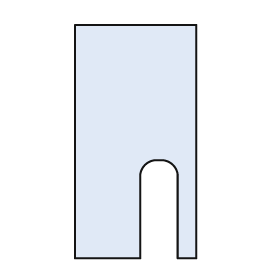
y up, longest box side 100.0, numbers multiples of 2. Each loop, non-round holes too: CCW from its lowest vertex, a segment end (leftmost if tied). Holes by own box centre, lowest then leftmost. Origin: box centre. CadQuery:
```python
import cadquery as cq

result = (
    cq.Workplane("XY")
    .moveTo(-26.0, -50.0)
    .lineTo(2.0, -50.0)
    .lineTo(2.0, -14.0)
    .threePointArc((4.0, -10.0), (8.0, -8.0))
    .lineTo(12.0, -8.0)
    .threePointArc((16.0, -10.0), (18.0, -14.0))
    .lineTo(18.0, -50.0)
    .lineTo(26.0, -50.0)
    .lineTo(26.0, 50.0)
    .lineTo(-26.0, 50.0)
    .close()
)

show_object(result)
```